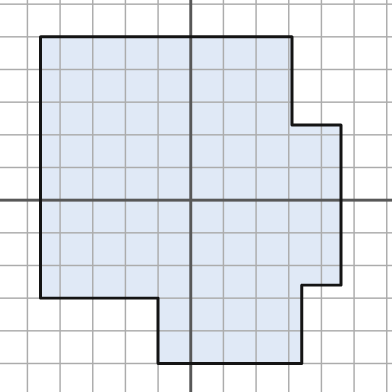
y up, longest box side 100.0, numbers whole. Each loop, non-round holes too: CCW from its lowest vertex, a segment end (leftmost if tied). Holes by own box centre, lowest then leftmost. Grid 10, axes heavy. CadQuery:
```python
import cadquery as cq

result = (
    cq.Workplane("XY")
    .moveTo(-10.0, -50.0)
    .lineTo(34.0, -50.0)
    .lineTo(34.0, -26.0)
    .lineTo(46.0, -26.0)
    .lineTo(46.0, 23.0)
    .lineTo(31.0, 23.0)
    .lineTo(31.0, 50.0)
    .lineTo(-46.0, 50.0)
    .lineTo(-46.0, -30.0)
    .lineTo(-10.0, -30.0)
    .close()
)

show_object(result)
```